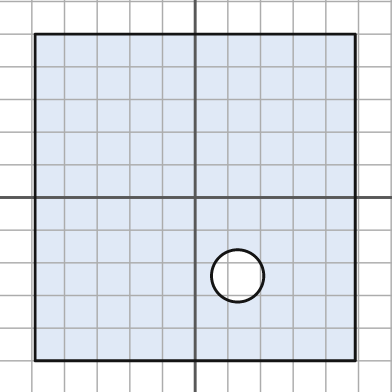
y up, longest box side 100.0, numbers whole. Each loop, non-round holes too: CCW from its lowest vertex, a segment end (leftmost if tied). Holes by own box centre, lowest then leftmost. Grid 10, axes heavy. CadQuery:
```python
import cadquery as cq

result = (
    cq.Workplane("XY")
    .moveTo(-49.0, -50.0)
    .lineTo(49.0, -50.0)
    .lineTo(49.0, 50.0)
    .lineTo(-49.0, 50.0)
    .close()
    .moveTo(13.0, -24.0)
    .circle(8.0)
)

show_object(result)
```